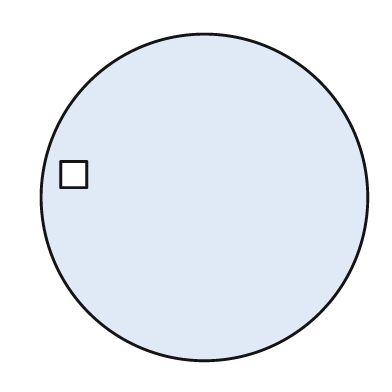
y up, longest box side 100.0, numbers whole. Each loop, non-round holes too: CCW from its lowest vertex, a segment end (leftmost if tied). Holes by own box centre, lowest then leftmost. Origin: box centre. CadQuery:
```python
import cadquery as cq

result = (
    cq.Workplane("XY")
    .moveTo(0.0, 0.0)
    .circle(50.0)
    .moveTo(-44.0, 3.0)
    .lineTo(-36.0, 3.0)
    .lineTo(-36.0, 11.0)
    .lineTo(-44.0, 11.0)
    .close()
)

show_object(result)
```